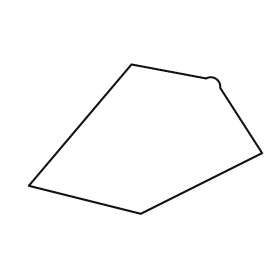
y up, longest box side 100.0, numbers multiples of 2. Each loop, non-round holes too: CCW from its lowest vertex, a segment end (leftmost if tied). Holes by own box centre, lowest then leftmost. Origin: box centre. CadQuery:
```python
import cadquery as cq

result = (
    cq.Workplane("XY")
    .moveTo(-2.0, -32.0)
    .lineTo(50.0, -6.0)
    .lineTo(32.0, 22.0)
    .threePointArc((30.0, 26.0), (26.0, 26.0))
    .lineTo(-6.0, 32.0)
    .lineTo(-50.0, -20.0)
    .close()
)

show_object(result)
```